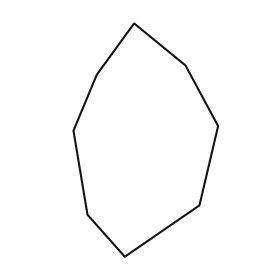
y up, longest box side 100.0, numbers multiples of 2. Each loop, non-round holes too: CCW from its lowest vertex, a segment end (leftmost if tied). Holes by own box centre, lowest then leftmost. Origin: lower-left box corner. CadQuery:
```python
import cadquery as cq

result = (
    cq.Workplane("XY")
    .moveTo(22.0, 0.0)
    .lineTo(54.0, 22.0)
    .lineTo(62.0, 56.0)
    .lineTo(48.0, 82.0)
    .lineTo(26.0, 100.0)
    .lineTo(10.0, 78.0)
    .lineTo(0.0, 54.0)
    .lineTo(6.0, 18.0)
    .close()
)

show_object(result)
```